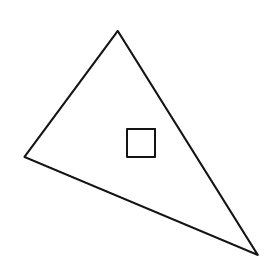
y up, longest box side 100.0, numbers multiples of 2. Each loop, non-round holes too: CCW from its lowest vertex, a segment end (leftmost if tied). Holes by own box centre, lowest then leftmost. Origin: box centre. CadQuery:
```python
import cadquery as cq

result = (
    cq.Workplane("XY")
    .moveTo(50.0, -48.0)
    .lineTo(-10.0, 48.0)
    .lineTo(-50.0, -6.0)
    .close()
    .moveTo(-6.0, -6.0)
    .lineTo(6.0, -6.0)
    .lineTo(6.0, 6.0)
    .lineTo(-6.0, 6.0)
    .close()
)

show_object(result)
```